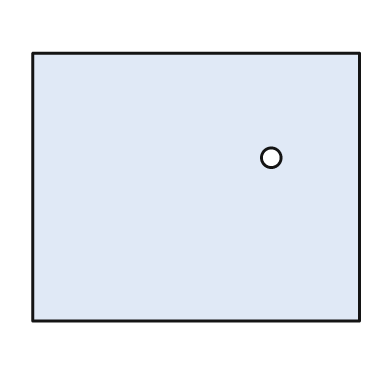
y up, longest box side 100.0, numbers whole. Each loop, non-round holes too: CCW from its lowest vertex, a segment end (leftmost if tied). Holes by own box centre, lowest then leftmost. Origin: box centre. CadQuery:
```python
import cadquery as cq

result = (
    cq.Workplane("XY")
    .moveTo(-50.0, -41.0)
    .lineTo(50.0, -41.0)
    .lineTo(50.0, 41.0)
    .lineTo(-50.0, 41.0)
    .close()
    .moveTo(23.0, 9.0)
    .circle(3.0)
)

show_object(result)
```